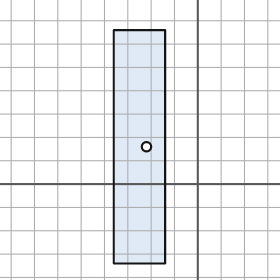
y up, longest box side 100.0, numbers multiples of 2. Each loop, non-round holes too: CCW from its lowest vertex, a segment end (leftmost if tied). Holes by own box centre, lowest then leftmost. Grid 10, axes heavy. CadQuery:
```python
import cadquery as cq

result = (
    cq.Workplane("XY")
    .moveTo(-36.0, -34.0)
    .lineTo(-14.0, -34.0)
    .lineTo(-14.0, 66.0)
    .lineTo(-36.0, 66.0)
    .close()
    .moveTo(-22.0, 16.0)
    .circle(2.0)
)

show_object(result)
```